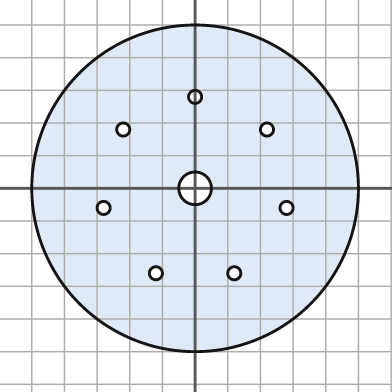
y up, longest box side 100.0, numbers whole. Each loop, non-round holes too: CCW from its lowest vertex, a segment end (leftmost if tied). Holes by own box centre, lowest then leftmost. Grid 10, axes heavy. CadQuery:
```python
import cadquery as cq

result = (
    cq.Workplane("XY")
    .moveTo(0.0, 0.0)
    .circle(50.0)
    .moveTo(-12.0, -26.0)
    .circle(2.0)
    .moveTo(12.0, -26.0)
    .circle(2.0)
    .moveTo(-28.0, -6.0)
    .circle(2.0)
    .moveTo(28.0, -6.0)
    .circle(2.0)
    .moveTo(0.0, 0.0)
    .circle(5.0)
    .moveTo(-22.0, 18.0)
    .circle(2.0)
    .moveTo(22.0, 18.0)
    .circle(2.0)
    .moveTo(0.0, 28.0)
    .circle(2.0)
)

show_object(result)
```